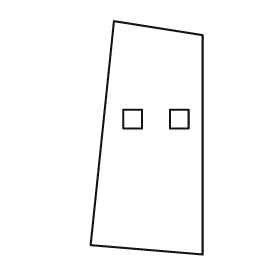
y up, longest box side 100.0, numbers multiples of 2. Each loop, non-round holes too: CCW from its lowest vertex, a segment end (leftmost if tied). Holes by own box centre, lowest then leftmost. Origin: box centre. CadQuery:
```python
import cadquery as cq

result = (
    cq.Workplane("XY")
    .moveTo(24.0, -50.0)
    .lineTo(24.0, 44.0)
    .lineTo(-14.0, 50.0)
    .lineTo(-24.0, -46.0)
    .close()
    .moveTo(-10.0, 4.0)
    .lineTo(-2.0, 4.0)
    .lineTo(-2.0, 12.0)
    .lineTo(-10.0, 12.0)
    .close()
    .moveTo(10.0, 4.0)
    .lineTo(18.0, 4.0)
    .lineTo(18.0, 12.0)
    .lineTo(10.0, 12.0)
    .close()
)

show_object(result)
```